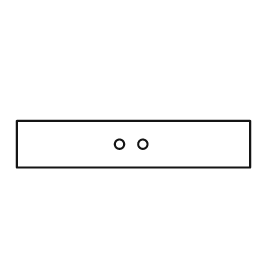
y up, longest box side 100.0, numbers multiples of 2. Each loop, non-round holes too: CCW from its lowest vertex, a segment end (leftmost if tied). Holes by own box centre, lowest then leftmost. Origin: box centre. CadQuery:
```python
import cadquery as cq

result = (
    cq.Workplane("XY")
    .moveTo(-50.0, -10.0)
    .lineTo(50.0, -10.0)
    .lineTo(50.0, 10.0)
    .lineTo(-50.0, 10.0)
    .close()
    .moveTo(-6.0, 0.0)
    .circle(2.0)
    .moveTo(4.0, 0.0)
    .circle(2.0)
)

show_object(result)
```